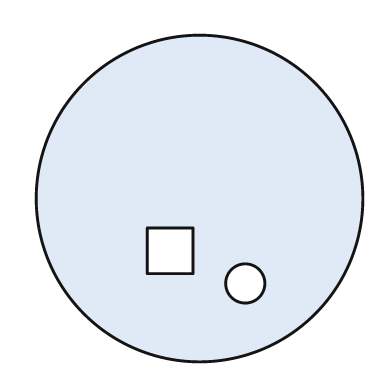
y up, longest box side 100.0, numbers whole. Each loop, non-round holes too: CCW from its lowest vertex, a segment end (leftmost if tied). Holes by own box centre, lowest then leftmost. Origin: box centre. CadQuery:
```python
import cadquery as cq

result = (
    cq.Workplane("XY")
    .moveTo(0.0, 0.0)
    .circle(50.0)
    .moveTo(14.0, -26.0)
    .circle(6.0)
    .moveTo(-16.0, -23.0)
    .lineTo(-2.0, -23.0)
    .lineTo(-2.0, -9.0)
    .lineTo(-16.0, -9.0)
    .close()
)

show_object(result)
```